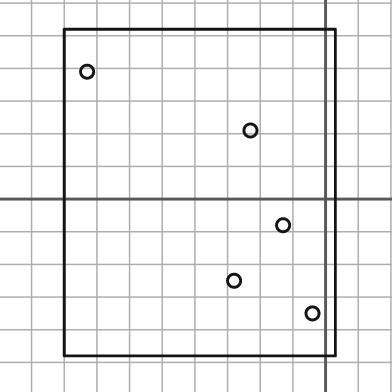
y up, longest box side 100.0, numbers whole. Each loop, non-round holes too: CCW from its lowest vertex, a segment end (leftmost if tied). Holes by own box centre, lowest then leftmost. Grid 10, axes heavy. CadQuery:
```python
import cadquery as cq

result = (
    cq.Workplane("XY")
    .moveTo(-80.0, -48.0)
    .lineTo(3.0, -48.0)
    .lineTo(3.0, 52.0)
    .lineTo(-80.0, 52.0)
    .close()
    .moveTo(-4.0, -35.0)
    .circle(2.0)
    .moveTo(-28.0, -25.0)
    .circle(2.0)
    .moveTo(-13.0, -8.0)
    .circle(2.0)
    .moveTo(-23.0, 21.0)
    .circle(2.0)
    .moveTo(-73.0, 39.0)
    .circle(2.0)
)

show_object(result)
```